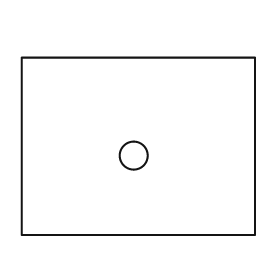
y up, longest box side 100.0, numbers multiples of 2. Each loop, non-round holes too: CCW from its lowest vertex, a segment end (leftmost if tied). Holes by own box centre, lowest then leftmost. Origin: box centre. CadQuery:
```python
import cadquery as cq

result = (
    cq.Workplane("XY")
    .moveTo(-50.0, -38.0)
    .lineTo(50.0, -38.0)
    .lineTo(50.0, 38.0)
    .lineTo(-50.0, 38.0)
    .close()
    .moveTo(-2.0, -4.0)
    .circle(6.0)
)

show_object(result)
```